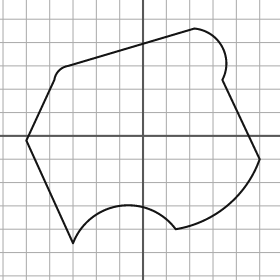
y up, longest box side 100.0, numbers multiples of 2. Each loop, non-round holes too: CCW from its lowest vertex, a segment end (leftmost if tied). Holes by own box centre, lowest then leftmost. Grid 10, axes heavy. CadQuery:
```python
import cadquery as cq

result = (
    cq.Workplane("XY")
    .moveTo(-30.0, -46.0)
    .threePointArc((-10.0, -30.0), (14.0, -40.0))
    .threePointArc((36.0, -30.0), (50.0, -10.0))
    .lineTo(34.0, 24.0)
    .threePointArc((34.0, 38.0), (22.0, 46.0))
    .lineTo(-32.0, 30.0)
    .threePointArc((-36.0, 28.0), (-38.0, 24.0))
    .lineTo(-50.0, -2.0)
    .close()
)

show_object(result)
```